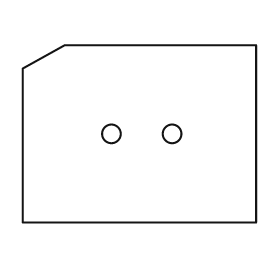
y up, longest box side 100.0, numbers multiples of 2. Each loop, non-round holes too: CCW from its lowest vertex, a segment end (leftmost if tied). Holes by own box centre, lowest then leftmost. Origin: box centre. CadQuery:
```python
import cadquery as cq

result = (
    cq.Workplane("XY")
    .moveTo(-50.0, -38.0)
    .lineTo(50.0, -38.0)
    .lineTo(50.0, 38.0)
    .lineTo(-32.0, 38.0)
    .lineTo(-50.0, 28.0)
    .close()
    .moveTo(-12.0, 0.0)
    .circle(4.0)
    .moveTo(14.0, 0.0)
    .circle(4.0)
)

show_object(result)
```